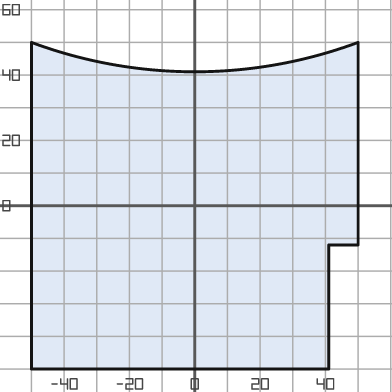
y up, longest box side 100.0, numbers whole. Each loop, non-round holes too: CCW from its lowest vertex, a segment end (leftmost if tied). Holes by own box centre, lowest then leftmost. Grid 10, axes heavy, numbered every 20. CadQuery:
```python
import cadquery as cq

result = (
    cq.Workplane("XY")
    .moveTo(-50.0, -50.0)
    .lineTo(41.0, -50.0)
    .lineTo(41.0, -12.0)
    .lineTo(50.0, -12.0)
    .lineTo(50.0, 50.0)
    .threePointArc((0.0, 41.0), (-50.0, 50.0))
    .close()
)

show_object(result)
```